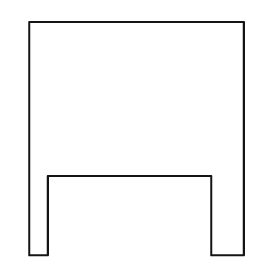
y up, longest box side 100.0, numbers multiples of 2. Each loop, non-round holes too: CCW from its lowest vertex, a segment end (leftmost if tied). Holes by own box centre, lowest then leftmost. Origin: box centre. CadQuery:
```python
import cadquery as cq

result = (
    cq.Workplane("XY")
    .moveTo(-46.0, -50.0)
    .lineTo(-38.0, -50.0)
    .lineTo(-38.0, -16.0)
    .lineTo(32.0, -16.0)
    .lineTo(32.0, -50.0)
    .lineTo(46.0, -50.0)
    .lineTo(46.0, 50.0)
    .lineTo(-46.0, 50.0)
    .close()
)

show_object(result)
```